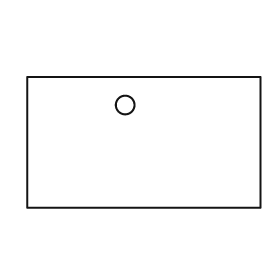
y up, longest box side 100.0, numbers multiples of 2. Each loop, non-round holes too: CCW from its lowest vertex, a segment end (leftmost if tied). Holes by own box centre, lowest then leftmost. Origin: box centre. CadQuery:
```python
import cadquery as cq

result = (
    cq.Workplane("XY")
    .moveTo(-50.0, -28.0)
    .lineTo(50.0, -28.0)
    .lineTo(50.0, 28.0)
    .lineTo(-50.0, 28.0)
    .close()
    .moveTo(-8.0, 16.0)
    .circle(4.0)
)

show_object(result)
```